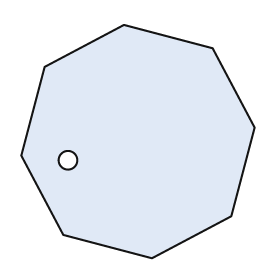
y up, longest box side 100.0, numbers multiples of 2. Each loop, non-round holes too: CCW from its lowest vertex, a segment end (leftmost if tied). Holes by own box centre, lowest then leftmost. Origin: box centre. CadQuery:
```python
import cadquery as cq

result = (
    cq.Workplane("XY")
    .moveTo(6.0, -50.0)
    .lineTo(40.0, -32.0)
    .lineTo(50.0, 6.0)
    .lineTo(32.0, 40.0)
    .lineTo(-6.0, 50.0)
    .lineTo(-40.0, 32.0)
    .lineTo(-50.0, -6.0)
    .lineTo(-32.0, -40.0)
    .close()
    .moveTo(-30.0, -8.0)
    .circle(4.0)
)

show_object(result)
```